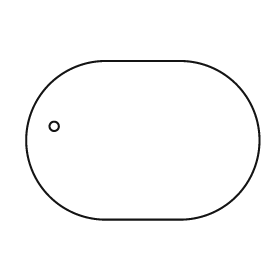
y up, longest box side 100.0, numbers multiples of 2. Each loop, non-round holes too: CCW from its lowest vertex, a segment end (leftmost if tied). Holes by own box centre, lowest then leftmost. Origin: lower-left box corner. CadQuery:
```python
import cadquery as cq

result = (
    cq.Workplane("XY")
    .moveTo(34.0, 0.0)
    .lineTo(66.0, 0.0)
    .threePointArc((100.0, 34.0), (66.0, 68.0))
    .lineTo(34.0, 68.0)
    .threePointArc((0.0, 34.0), (34.0, 0.0))
    .close()
    .moveTo(12.0, 40.0)
    .circle(2.0)
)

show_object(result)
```